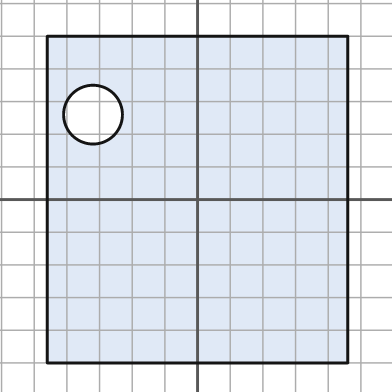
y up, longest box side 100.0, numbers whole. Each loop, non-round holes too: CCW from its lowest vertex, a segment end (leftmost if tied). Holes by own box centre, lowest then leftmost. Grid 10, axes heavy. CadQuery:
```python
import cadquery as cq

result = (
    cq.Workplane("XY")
    .moveTo(-46.0, -50.0)
    .lineTo(46.0, -50.0)
    .lineTo(46.0, 50.0)
    .lineTo(-46.0, 50.0)
    .close()
    .moveTo(-32.0, 26.0)
    .circle(9.0)
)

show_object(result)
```